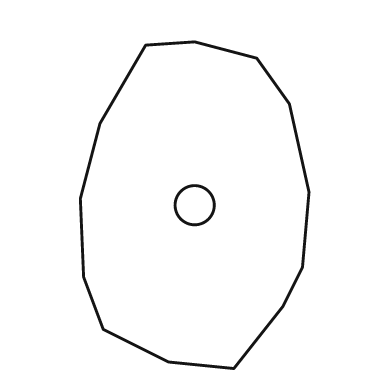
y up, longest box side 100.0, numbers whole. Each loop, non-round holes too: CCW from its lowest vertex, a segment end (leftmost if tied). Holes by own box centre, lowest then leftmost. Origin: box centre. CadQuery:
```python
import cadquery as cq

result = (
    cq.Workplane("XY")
    .moveTo(12.0, -50.0)
    .lineTo(27.0, -31.0)
    .lineTo(33.0, -19.0)
    .lineTo(35.0, 4.0)
    .lineTo(29.0, 31.0)
    .lineTo(19.0, 45.0)
    .lineTo(0.0, 50.0)
    .lineTo(-15.0, 49.0)
    .lineTo(-29.0, 25.0)
    .lineTo(-35.0, 2.0)
    .lineTo(-34.0, -22.0)
    .lineTo(-28.0, -38.0)
    .lineTo(-8.0, -48.0)
    .close()
    .moveTo(0.0, 0.0)
    .circle(6.0)
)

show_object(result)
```